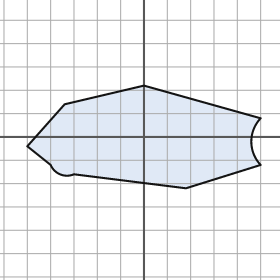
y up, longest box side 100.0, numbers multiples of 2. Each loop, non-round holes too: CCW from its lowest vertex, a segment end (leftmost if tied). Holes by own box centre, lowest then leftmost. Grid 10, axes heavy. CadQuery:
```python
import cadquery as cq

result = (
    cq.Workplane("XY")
    .moveTo(18.0, -22.0)
    .lineTo(50.0, -12.0)
    .threePointArc((46.0, -2.0), (50.0, 8.0))
    .lineTo(0.0, 22.0)
    .lineTo(-34.0, 14.0)
    .lineTo(-50.0, -4.0)
    .lineTo(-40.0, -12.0)
    .threePointArc((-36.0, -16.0), (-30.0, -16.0))
    .close()
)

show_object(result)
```